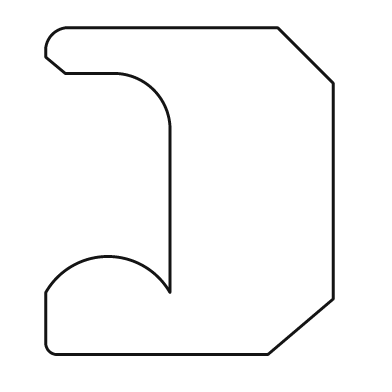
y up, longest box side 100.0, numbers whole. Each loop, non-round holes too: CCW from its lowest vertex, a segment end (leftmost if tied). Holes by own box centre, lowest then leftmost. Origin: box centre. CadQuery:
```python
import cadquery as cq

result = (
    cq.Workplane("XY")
    .moveTo(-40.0, -50.0)
    .lineTo(24.0, -50.0)
    .lineTo(44.0, -33.0)
    .lineTo(44.0, 33.0)
    .lineTo(27.0, 50.0)
    .lineTo(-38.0, 50.0)
    .threePointArc((-42.0, 48.0), (-44.0, 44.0))
    .lineTo(-44.0, 41.0)
    .lineTo(-38.0, 36.0)
    .lineTo(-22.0, 36.0)
    .threePointArc((-11.0, 31.0), (-6.0, 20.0))
    .lineTo(-6.0, -31.0)
    .threePointArc((-25.0, -20.0), (-44.0, -31.0))
    .lineTo(-44.0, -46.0)
    .threePointArc((-43.0, -49.0), (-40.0, -50.0))
    .close()
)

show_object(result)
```